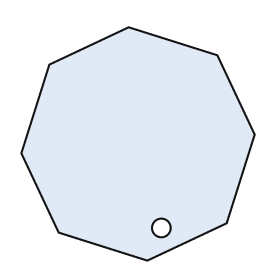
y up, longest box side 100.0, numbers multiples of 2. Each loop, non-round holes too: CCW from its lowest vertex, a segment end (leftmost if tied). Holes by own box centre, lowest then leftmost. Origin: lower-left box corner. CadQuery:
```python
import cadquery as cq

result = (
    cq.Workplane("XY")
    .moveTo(54.0, 0.0)
    .lineTo(88.0, 16.0)
    .lineTo(100.0, 54.0)
    .lineTo(84.0, 88.0)
    .lineTo(46.0, 100.0)
    .lineTo(12.0, 84.0)
    .lineTo(0.0, 46.0)
    .lineTo(16.0, 12.0)
    .close()
    .moveTo(60.0, 14.0)
    .circle(4.0)
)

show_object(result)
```